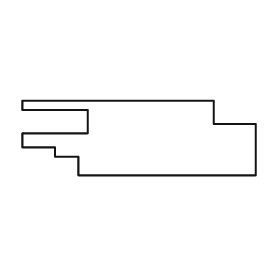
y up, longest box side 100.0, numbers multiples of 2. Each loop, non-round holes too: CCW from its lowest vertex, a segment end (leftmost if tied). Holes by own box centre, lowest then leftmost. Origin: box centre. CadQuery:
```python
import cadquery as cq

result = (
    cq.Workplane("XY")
    .moveTo(-26.0, -16.0)
    .lineTo(50.0, -16.0)
    .lineTo(50.0, 6.0)
    .lineTo(32.0, 6.0)
    .lineTo(32.0, 16.0)
    .lineTo(-50.0, 16.0)
    .lineTo(-50.0, 12.0)
    .lineTo(-22.0, 12.0)
    .lineTo(-22.0, 2.0)
    .lineTo(-50.0, 2.0)
    .lineTo(-50.0, -4.0)
    .lineTo(-36.0, -4.0)
    .lineTo(-36.0, -8.0)
    .lineTo(-26.0, -8.0)
    .close()
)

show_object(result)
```